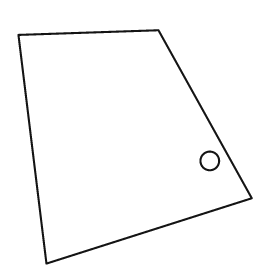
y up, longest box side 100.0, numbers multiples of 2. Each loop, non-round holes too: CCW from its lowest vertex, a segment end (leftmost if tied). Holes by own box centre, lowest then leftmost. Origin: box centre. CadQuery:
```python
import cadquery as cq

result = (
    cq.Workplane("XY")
    .moveTo(-38.0, -50.0)
    .lineTo(50.0, -22.0)
    .lineTo(10.0, 50.0)
    .lineTo(-50.0, 48.0)
    .close()
    .moveTo(32.0, -6.0)
    .circle(4.0)
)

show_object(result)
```